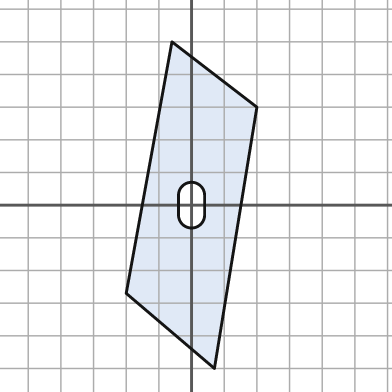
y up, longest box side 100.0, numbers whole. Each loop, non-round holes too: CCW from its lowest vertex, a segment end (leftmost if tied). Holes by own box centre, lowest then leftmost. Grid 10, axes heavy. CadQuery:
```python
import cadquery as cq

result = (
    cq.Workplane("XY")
    .moveTo(7.0, -50.0)
    .lineTo(20.0, 30.0)
    .lineTo(-6.0, 50.0)
    .lineTo(-20.0, -27.0)
    .close()
    .moveTo(-4.0, -3.0)
    .threePointArc((0.0, -7.0), (4.0, -3.0))
    .lineTo(4.0, 3.0)
    .threePointArc((0.0, 7.0), (-4.0, 3.0))
    .close()
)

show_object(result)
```